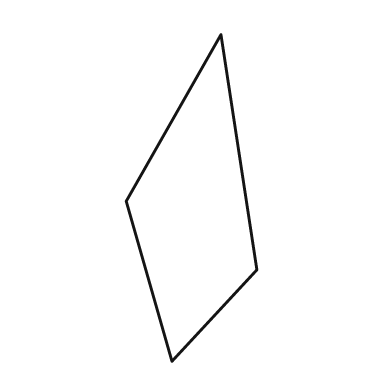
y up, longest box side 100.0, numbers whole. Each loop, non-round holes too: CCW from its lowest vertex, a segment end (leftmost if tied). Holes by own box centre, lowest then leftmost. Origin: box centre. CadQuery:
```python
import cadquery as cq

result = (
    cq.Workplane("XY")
    .moveTo(-6.0, -50.0)
    .lineTo(20.0, -22.0)
    .lineTo(9.0, 50.0)
    .lineTo(-20.0, -1.0)
    .close()
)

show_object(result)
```